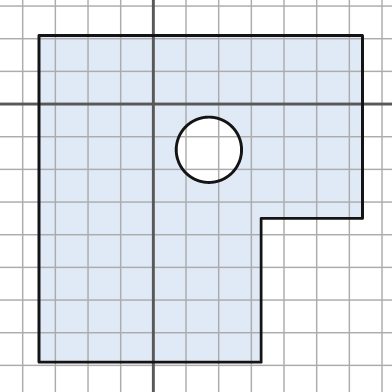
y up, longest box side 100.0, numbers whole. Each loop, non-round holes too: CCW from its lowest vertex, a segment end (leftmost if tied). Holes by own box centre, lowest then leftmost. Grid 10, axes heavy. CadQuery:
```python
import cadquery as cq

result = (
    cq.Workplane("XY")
    .moveTo(-35.0, -79.0)
    .lineTo(33.0, -79.0)
    .lineTo(33.0, -35.0)
    .lineTo(64.0, -35.0)
    .lineTo(64.0, 21.0)
    .lineTo(-35.0, 21.0)
    .close()
    .moveTo(17.0, -14.0)
    .circle(10.0)
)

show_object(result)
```